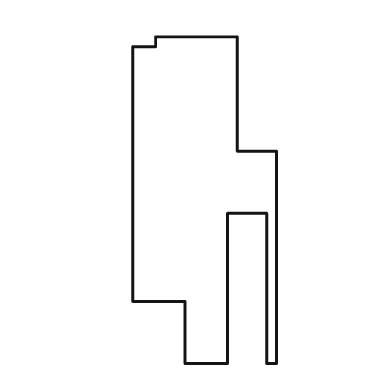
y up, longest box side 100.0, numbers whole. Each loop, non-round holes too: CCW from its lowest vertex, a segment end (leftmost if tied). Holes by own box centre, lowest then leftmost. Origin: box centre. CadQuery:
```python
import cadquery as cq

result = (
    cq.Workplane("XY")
    .moveTo(-6.0, -50.0)
    .lineTo(7.0, -50.0)
    .lineTo(7.0, -4.0)
    .lineTo(19.0, -4.0)
    .lineTo(19.0, -50.0)
    .lineTo(22.0, -50.0)
    .lineTo(22.0, 15.0)
    .lineTo(10.0, 15.0)
    .lineTo(10.0, 50.0)
    .lineTo(-15.0, 50.0)
    .lineTo(-15.0, 47.0)
    .lineTo(-22.0, 47.0)
    .lineTo(-22.0, -31.0)
    .lineTo(-6.0, -31.0)
    .close()
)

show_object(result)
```